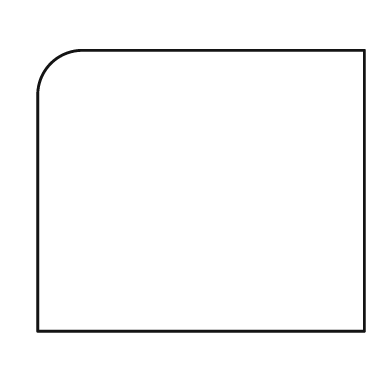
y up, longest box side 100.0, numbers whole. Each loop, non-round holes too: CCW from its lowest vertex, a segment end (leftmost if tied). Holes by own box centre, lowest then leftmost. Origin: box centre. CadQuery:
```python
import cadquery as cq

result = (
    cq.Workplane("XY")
    .moveTo(-50.0, -43.0)
    .lineTo(50.0, -43.0)
    .lineTo(50.0, 43.0)
    .lineTo(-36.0, 43.0)
    .threePointArc((-46.0, 39.0), (-50.0, 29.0))
    .close()
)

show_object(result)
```